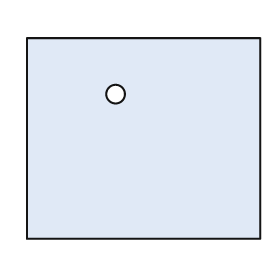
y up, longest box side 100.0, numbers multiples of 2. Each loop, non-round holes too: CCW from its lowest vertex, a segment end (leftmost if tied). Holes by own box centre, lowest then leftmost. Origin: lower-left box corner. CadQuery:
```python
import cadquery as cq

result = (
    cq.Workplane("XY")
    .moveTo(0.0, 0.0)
    .lineTo(100.0, 0.0)
    .lineTo(100.0, 86.0)
    .lineTo(0.0, 86.0)
    .close()
    .moveTo(38.0, 62.0)
    .circle(4.0)
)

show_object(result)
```